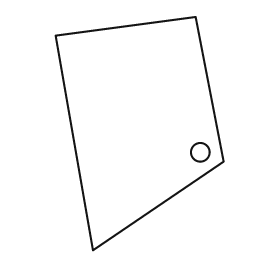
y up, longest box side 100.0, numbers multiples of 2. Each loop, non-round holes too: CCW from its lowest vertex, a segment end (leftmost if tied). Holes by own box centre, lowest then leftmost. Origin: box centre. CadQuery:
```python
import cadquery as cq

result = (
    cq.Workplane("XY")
    .moveTo(-20.0, -50.0)
    .lineTo(36.0, -12.0)
    .lineTo(24.0, 50.0)
    .lineTo(-36.0, 42.0)
    .close()
    .moveTo(26.0, -8.0)
    .circle(4.0)
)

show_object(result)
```